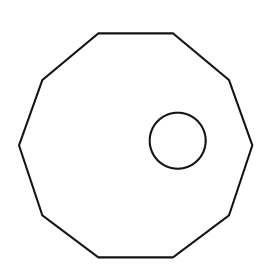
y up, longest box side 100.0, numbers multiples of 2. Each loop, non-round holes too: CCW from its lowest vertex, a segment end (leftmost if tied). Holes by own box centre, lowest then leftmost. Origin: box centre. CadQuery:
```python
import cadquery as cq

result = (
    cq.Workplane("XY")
    .moveTo(-16.0, -48.0)
    .lineTo(16.0, -48.0)
    .lineTo(40.0, -30.0)
    .lineTo(50.0, 0.0)
    .lineTo(40.0, 28.0)
    .lineTo(16.0, 48.0)
    .lineTo(-16.0, 48.0)
    .lineTo(-40.0, 28.0)
    .lineTo(-50.0, 0.0)
    .lineTo(-40.0, -30.0)
    .close()
    .moveTo(18.0, 2.0)
    .circle(12.0)
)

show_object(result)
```